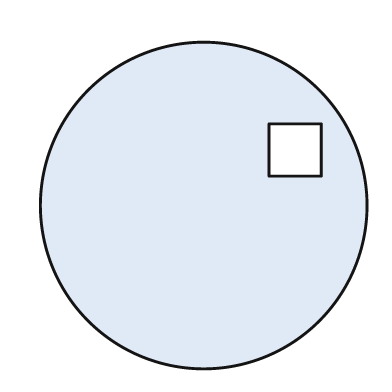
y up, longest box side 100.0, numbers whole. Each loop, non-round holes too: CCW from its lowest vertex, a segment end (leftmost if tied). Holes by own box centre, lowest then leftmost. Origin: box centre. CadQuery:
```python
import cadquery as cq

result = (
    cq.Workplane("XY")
    .moveTo(0.0, 0.0)
    .circle(50.0)
    .moveTo(20.0, 9.0)
    .lineTo(36.0, 9.0)
    .lineTo(36.0, 25.0)
    .lineTo(20.0, 25.0)
    .close()
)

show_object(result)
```